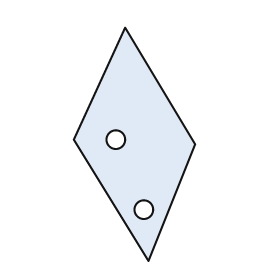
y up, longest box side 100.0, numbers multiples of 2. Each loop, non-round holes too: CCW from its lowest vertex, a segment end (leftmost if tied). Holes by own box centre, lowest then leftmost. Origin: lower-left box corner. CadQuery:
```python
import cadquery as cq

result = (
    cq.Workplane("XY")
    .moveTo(32.0, 0.0)
    .lineTo(52.0, 50.0)
    .lineTo(22.0, 100.0)
    .lineTo(0.0, 52.0)
    .close()
    .moveTo(30.0, 22.0)
    .circle(4.0)
    .moveTo(18.0, 52.0)
    .circle(4.0)
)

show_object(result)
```